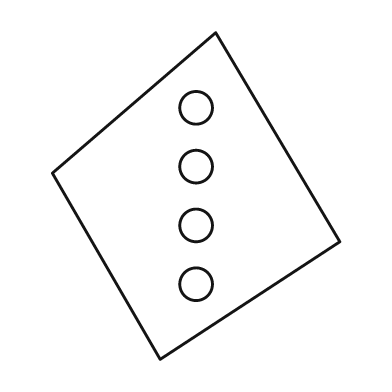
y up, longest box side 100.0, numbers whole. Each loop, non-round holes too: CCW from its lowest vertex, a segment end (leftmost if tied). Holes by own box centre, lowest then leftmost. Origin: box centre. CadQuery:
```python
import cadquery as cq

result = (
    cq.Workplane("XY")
    .moveTo(-11.0, -50.0)
    .lineTo(44.0, -14.0)
    .lineTo(6.0, 50.0)
    .lineTo(-44.0, 7.0)
    .close()
    .moveTo(0.0, -27.0)
    .circle(5.0)
    .moveTo(0.0, -9.0)
    .circle(5.0)
    .moveTo(0.0, 9.0)
    .circle(5.0)
    .moveTo(0.0, 27.0)
    .circle(5.0)
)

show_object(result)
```